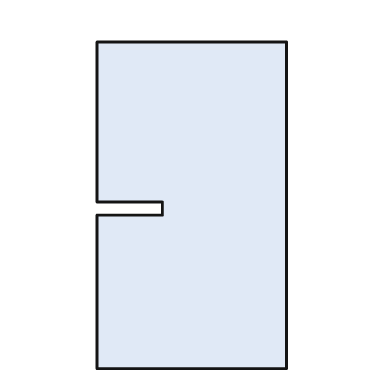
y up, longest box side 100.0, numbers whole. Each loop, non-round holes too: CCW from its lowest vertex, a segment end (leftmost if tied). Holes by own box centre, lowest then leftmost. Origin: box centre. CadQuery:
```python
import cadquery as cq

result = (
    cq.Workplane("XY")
    .moveTo(-29.0, -50.0)
    .lineTo(29.0, -50.0)
    .lineTo(29.0, 50.0)
    .lineTo(-29.0, 50.0)
    .lineTo(-29.0, 1.0)
    .lineTo(-9.0, 1.0)
    .lineTo(-9.0, -3.0)
    .lineTo(-29.0, -3.0)
    .close()
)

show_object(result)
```